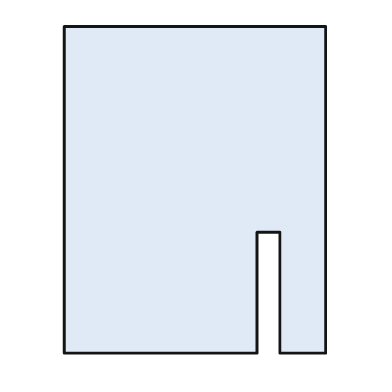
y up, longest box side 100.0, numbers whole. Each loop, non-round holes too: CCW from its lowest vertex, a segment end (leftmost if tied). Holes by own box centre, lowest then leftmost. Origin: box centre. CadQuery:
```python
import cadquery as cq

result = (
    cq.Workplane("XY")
    .moveTo(-40.0, -50.0)
    .lineTo(19.0, -50.0)
    .lineTo(19.0, -13.0)
    .lineTo(26.0, -13.0)
    .lineTo(26.0, -50.0)
    .lineTo(40.0, -50.0)
    .lineTo(40.0, 50.0)
    .lineTo(-40.0, 50.0)
    .close()
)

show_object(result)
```